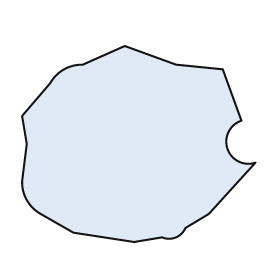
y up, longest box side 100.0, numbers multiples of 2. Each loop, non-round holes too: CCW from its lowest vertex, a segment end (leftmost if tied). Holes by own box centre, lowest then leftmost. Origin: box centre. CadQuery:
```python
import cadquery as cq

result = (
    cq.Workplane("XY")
    .moveTo(-2.0, -42.0)
    .lineTo(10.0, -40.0)
    .threePointArc((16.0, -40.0), (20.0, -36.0))
    .lineTo(30.0, -30.0)
    .lineTo(50.0, -8.0)
    .threePointArc((38.0, -2.0), (44.0, 10.0))
    .lineTo(36.0, 32.0)
    .lineTo(16.0, 34.0)
    .lineTo(-6.0, 42.0)
    .lineTo(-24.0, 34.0)
    .threePointArc((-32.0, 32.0), (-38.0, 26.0))
    .lineTo(-50.0, 12.0)
    .lineTo(-48.0, 0.0)
    .lineTo(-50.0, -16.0)
    .threePointArc((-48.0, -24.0), (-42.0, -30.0))
    .lineTo(-28.0, -38.0)
    .close()
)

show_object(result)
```